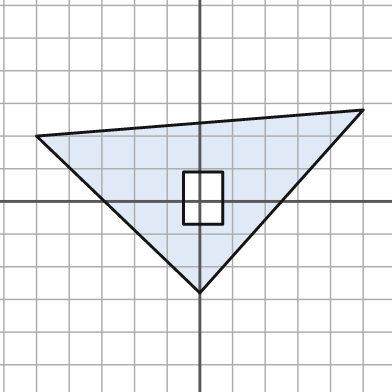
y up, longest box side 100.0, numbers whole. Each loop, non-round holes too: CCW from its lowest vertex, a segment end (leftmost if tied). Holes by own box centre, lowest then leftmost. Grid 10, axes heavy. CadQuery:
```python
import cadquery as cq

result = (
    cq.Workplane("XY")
    .moveTo(0.0, -28.0)
    .lineTo(50.0, 28.0)
    .lineTo(-50.0, 20.0)
    .close()
    .moveTo(-5.0, -7.0)
    .lineTo(7.0, -7.0)
    .lineTo(7.0, 9.0)
    .lineTo(-5.0, 9.0)
    .close()
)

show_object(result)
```